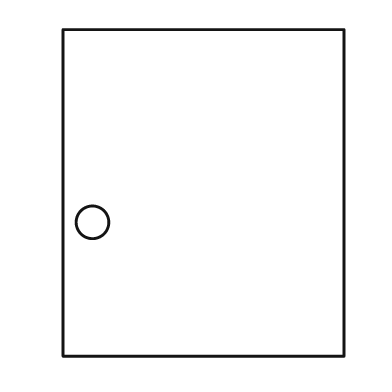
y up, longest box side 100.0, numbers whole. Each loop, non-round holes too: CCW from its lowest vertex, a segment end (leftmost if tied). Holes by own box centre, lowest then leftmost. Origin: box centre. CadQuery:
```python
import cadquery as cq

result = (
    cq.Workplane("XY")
    .moveTo(-43.0, -50.0)
    .lineTo(43.0, -50.0)
    .lineTo(43.0, 50.0)
    .lineTo(-43.0, 50.0)
    .close()
    .moveTo(-34.0, -9.0)
    .circle(5.0)
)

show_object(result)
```